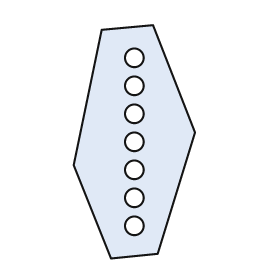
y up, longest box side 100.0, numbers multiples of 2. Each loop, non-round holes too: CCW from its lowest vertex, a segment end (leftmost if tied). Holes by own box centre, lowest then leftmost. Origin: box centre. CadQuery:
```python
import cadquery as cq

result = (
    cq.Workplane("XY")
    .moveTo(-10.0, -50.0)
    .lineTo(10.0, -48.0)
    .lineTo(26.0, 4.0)
    .lineTo(8.0, 50.0)
    .lineTo(-14.0, 48.0)
    .lineTo(-26.0, -10.0)
    .close()
    .moveTo(0.0, -36.0)
    .circle(4.0)
    .moveTo(0.0, -24.0)
    .circle(4.0)
    .moveTo(0.0, -12.0)
    .circle(4.0)
    .moveTo(0.0, 0.0)
    .circle(4.0)
    .moveTo(0.0, 12.0)
    .circle(4.0)
    .moveTo(0.0, 24.0)
    .circle(4.0)
    .moveTo(0.0, 36.0)
    .circle(4.0)
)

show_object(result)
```